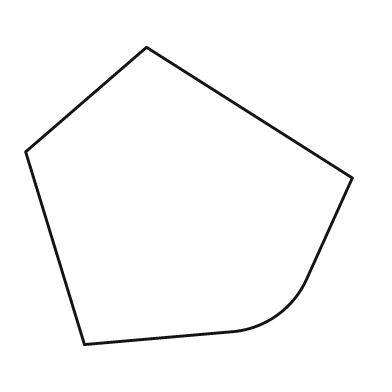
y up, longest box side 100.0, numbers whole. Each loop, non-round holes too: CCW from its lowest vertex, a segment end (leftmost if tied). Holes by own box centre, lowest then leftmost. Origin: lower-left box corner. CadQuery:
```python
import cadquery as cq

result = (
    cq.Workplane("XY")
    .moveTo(18.0, 0.0)
    .lineTo(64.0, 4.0)
    .threePointArc((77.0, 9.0), (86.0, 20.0))
    .lineTo(100.0, 51.0)
    .lineTo(37.0, 91.0)
    .lineTo(0.0, 59.0)
    .close()
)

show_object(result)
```